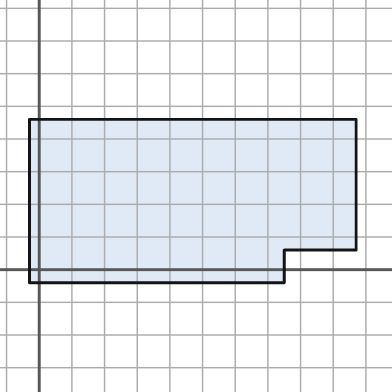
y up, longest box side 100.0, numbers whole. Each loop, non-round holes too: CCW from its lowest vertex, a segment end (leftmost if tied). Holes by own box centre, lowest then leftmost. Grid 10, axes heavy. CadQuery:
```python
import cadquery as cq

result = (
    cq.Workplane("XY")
    .moveTo(-3.0, -4.0)
    .lineTo(75.0, -4.0)
    .lineTo(75.0, 6.0)
    .lineTo(97.0, 6.0)
    .lineTo(97.0, 46.0)
    .lineTo(-3.0, 46.0)
    .close()
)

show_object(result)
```